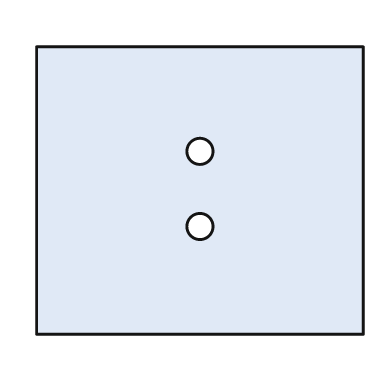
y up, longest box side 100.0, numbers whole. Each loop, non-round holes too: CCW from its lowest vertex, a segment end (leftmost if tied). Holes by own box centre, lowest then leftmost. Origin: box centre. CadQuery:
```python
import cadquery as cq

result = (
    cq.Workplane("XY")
    .moveTo(-50.0, -44.0)
    .lineTo(50.0, -44.0)
    .lineTo(50.0, 44.0)
    .lineTo(-50.0, 44.0)
    .close()
    .moveTo(0.0, -11.0)
    .circle(4.0)
    .moveTo(0.0, 12.0)
    .circle(4.0)
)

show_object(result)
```